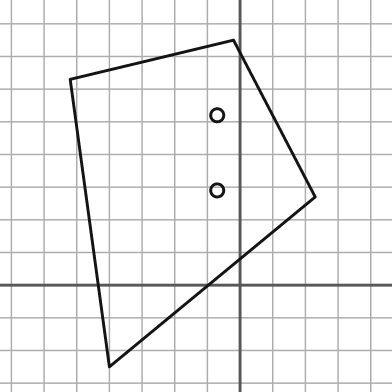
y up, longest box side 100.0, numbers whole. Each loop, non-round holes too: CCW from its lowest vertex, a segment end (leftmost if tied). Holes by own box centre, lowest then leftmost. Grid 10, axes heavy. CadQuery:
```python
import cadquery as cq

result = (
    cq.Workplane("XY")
    .moveTo(-40.0, -25.0)
    .lineTo(23.0, 27.0)
    .lineTo(-2.0, 75.0)
    .lineTo(-52.0, 63.0)
    .close()
    .moveTo(-7.0, 29.0)
    .circle(2.0)
    .moveTo(-7.0, 52.0)
    .circle(2.0)
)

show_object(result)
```